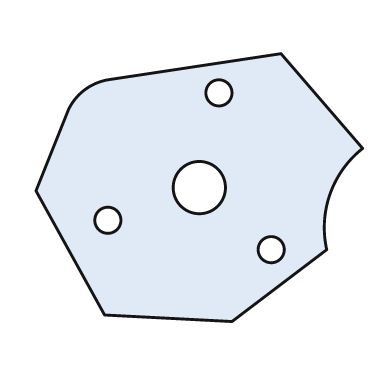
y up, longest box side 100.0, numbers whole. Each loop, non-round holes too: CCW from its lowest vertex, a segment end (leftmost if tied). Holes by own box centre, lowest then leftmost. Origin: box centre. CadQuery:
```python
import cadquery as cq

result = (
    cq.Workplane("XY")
    .moveTo(10.0, -41.0)
    .lineTo(39.0, -19.0)
    .threePointArc((40.0, -2.0), (50.0, 12.0))
    .lineTo(25.0, 41.0)
    .lineTo(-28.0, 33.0)
    .threePointArc((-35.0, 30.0), (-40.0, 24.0))
    .lineTo(-50.0, -1.0)
    .lineTo(-29.0, -39.0)
    .close()
    .moveTo(22.0, -19.0)
    .circle(4.0)
    .moveTo(-28.0, -10.0)
    .circle(4.0)
    .moveTo(0.0, 0.0)
    .circle(8.0)
    .moveTo(6.0, 29.0)
    .circle(4.0)
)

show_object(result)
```